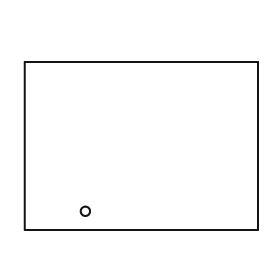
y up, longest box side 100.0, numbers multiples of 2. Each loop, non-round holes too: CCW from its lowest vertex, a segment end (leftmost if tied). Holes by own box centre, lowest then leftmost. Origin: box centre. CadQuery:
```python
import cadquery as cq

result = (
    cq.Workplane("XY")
    .moveTo(-50.0, -36.0)
    .lineTo(50.0, -36.0)
    .lineTo(50.0, 36.0)
    .lineTo(-50.0, 36.0)
    .close()
    .moveTo(-24.0, -28.0)
    .circle(2.0)
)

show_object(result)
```